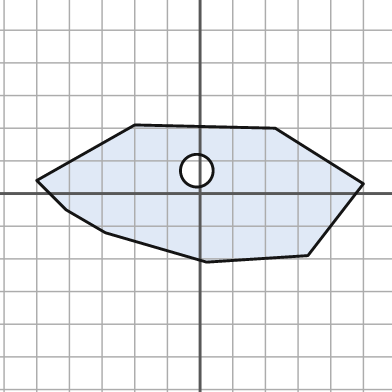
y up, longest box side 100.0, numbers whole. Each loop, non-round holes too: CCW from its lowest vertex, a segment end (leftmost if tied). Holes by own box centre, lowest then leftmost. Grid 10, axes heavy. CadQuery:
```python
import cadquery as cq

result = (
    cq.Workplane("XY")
    .moveTo(2.0, -21.0)
    .lineTo(33.0, -19.0)
    .lineTo(50.0, 3.0)
    .lineTo(23.0, 20.0)
    .lineTo(-20.0, 21.0)
    .lineTo(-50.0, 4.0)
    .lineTo(-41.0, -5.0)
    .lineTo(-29.0, -12.0)
    .close()
    .moveTo(-1.0, 7.0)
    .circle(5.0)
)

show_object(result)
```